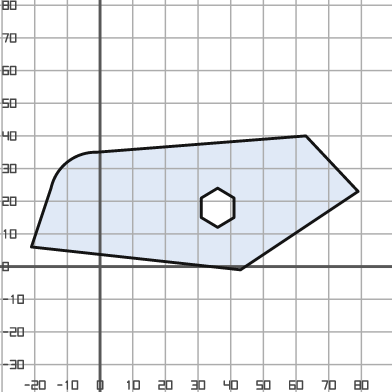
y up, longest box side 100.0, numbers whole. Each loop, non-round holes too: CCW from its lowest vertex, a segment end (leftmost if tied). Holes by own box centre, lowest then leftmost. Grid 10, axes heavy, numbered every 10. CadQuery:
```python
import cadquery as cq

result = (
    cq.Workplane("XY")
    .moveTo(43.0, -1.0)
    .lineTo(79.0, 23.0)
    .lineTo(63.0, 40.0)
    .lineTo(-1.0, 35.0)
    .threePointArc((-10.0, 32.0), (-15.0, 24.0))
    .lineTo(-21.0, 6.0)
    .close()
    .moveTo(36.0, 12.0)
    .lineTo(41.0, 15.0)
    .lineTo(41.0, 21.0)
    .lineTo(36.0, 24.0)
    .lineTo(31.0, 21.0)
    .lineTo(31.0, 15.0)
    .close()
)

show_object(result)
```